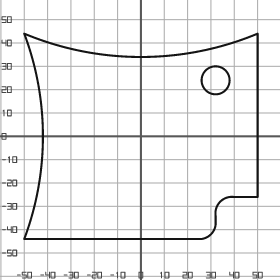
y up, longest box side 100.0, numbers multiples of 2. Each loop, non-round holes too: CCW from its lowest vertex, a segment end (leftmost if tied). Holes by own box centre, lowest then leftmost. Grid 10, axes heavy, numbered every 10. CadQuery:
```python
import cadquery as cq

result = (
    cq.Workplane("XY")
    .moveTo(-50.0, -44.0)
    .lineTo(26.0, -44.0)
    .threePointArc((30.0, -42.0), (32.0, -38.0))
    .lineTo(32.0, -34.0)
    .threePointArc((34.0, -28.0), (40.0, -26.0))
    .lineTo(50.0, -26.0)
    .lineTo(50.0, 44.0)
    .threePointArc((0.0, 34.0), (-50.0, 44.0))
    .threePointArc((-42.0, 0.0), (-50.0, -44.0))
    .close()
    .moveTo(32.0, 24.0)
    .circle(6.0)
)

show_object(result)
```